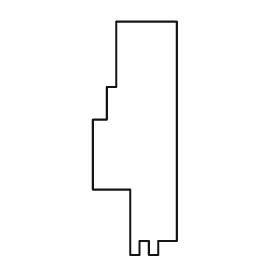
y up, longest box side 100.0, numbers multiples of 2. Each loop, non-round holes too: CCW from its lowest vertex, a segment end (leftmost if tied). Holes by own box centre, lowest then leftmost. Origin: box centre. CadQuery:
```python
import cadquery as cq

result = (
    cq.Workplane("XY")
    .moveTo(-2.0, -50.0)
    .lineTo(2.0, -50.0)
    .lineTo(2.0, -44.0)
    .lineTo(6.0, -44.0)
    .lineTo(6.0, -50.0)
    .lineTo(10.0, -50.0)
    .lineTo(10.0, -44.0)
    .lineTo(18.0, -44.0)
    .lineTo(18.0, 50.0)
    .lineTo(-8.0, 50.0)
    .lineTo(-8.0, 22.0)
    .lineTo(-12.0, 22.0)
    .lineTo(-12.0, 8.0)
    .lineTo(-18.0, 8.0)
    .lineTo(-18.0, -22.0)
    .lineTo(-2.0, -22.0)
    .close()
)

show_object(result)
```